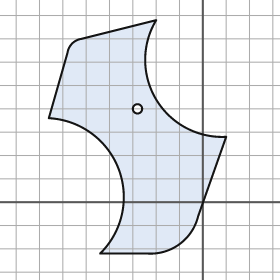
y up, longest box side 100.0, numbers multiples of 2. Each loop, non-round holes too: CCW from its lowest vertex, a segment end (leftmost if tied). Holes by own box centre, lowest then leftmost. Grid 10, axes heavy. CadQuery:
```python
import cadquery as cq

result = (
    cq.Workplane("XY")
    .moveTo(-44.0, -22.0)
    .lineTo(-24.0, -22.0)
    .threePointArc((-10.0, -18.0), (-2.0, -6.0))
    .lineTo(10.0, 28.0)
    .threePointArc((-20.0, 44.0), (-20.0, 78.0))
    .lineTo(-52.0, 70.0)
    .threePointArc((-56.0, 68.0), (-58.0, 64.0))
    .lineTo(-66.0, 36.0)
    .threePointArc((-36.0, 14.0), (-44.0, -22.0))
    .close()
    .moveTo(-28.0, 40.0)
    .circle(2.0)
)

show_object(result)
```